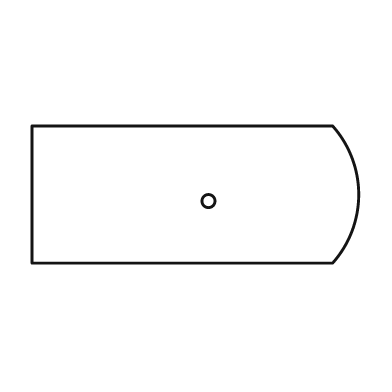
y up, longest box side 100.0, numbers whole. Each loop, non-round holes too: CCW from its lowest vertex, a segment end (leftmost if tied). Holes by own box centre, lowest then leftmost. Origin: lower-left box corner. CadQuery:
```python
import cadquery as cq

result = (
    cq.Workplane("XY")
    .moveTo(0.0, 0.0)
    .lineTo(92.0, 0.0)
    .threePointArc((100.0, 21.0), (92.0, 42.0))
    .lineTo(0.0, 42.0)
    .close()
    .moveTo(54.0, 19.0)
    .circle(2.0)
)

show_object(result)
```